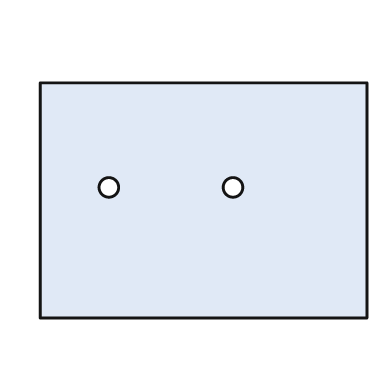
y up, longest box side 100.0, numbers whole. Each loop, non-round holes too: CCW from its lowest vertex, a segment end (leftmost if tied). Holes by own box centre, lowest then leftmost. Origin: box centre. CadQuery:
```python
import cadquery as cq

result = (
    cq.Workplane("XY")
    .moveTo(-50.0, -36.0)
    .lineTo(50.0, -36.0)
    .lineTo(50.0, 36.0)
    .lineTo(-50.0, 36.0)
    .close()
    .moveTo(-29.0, 4.0)
    .circle(3.0)
    .moveTo(9.0, 4.0)
    .circle(3.0)
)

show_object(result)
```